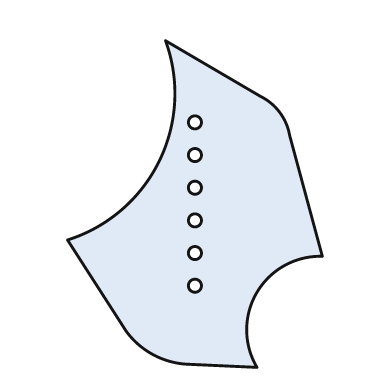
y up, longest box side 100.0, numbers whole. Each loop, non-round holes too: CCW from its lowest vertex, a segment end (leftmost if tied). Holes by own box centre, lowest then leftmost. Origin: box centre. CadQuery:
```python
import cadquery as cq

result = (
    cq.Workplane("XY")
    .moveTo(19.0, -50.0)
    .threePointArc((19.0, -27.0), (39.0, -16.0))
    .lineTo(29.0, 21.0)
    .threePointArc((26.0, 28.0), (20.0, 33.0))
    .lineTo(-9.0, 50.0)
    .threePointArc((-11.0, 13.0), (-39.0, -11.0))
    .lineTo(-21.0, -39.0)
    .threePointArc((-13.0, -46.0), (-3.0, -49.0))
    .close()
    .moveTo(0.0, -25.0)
    .circle(2.0)
    .moveTo(0.0, -15.0)
    .circle(2.0)
    .moveTo(0.0, -5.0)
    .circle(2.0)
    .moveTo(0.0, 5.0)
    .circle(2.0)
    .moveTo(0.0, 15.0)
    .circle(2.0)
    .moveTo(0.0, 25.0)
    .circle(2.0)
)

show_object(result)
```